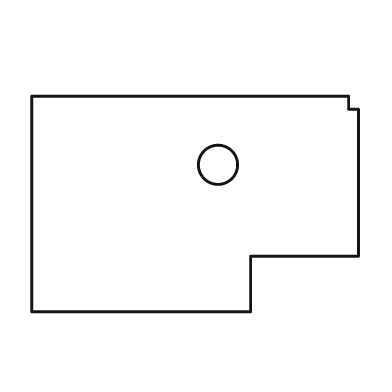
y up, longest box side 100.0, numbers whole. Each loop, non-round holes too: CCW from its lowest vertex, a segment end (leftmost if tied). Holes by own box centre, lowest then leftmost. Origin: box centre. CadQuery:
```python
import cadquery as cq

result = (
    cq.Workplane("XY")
    .moveTo(-50.0, -33.0)
    .lineTo(17.0, -33.0)
    .lineTo(17.0, -16.0)
    .lineTo(50.0, -16.0)
    .lineTo(50.0, 29.0)
    .lineTo(47.0, 29.0)
    .lineTo(47.0, 33.0)
    .lineTo(-50.0, 33.0)
    .close()
    .moveTo(7.0, 12.0)
    .circle(6.0)
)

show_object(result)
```